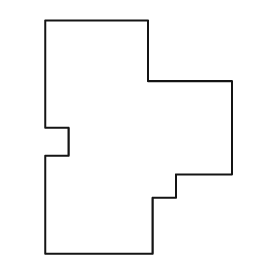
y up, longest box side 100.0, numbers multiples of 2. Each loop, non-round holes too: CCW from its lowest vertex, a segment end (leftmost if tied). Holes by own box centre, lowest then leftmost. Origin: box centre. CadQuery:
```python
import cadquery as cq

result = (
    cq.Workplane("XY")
    .moveTo(-40.0, -50.0)
    .lineTo(6.0, -50.0)
    .lineTo(6.0, -26.0)
    .lineTo(16.0, -26.0)
    .lineTo(16.0, -16.0)
    .lineTo(40.0, -16.0)
    .lineTo(40.0, 24.0)
    .lineTo(4.0, 24.0)
    .lineTo(4.0, 50.0)
    .lineTo(-40.0, 50.0)
    .lineTo(-40.0, 4.0)
    .lineTo(-30.0, 4.0)
    .lineTo(-30.0, -8.0)
    .lineTo(-40.0, -8.0)
    .close()
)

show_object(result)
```